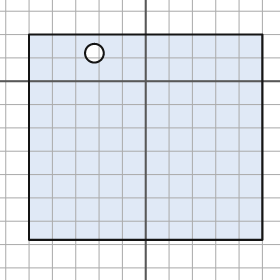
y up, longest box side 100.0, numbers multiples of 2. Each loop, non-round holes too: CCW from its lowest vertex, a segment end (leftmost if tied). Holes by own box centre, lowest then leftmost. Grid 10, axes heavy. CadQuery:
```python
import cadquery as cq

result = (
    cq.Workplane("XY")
    .moveTo(-50.0, -68.0)
    .lineTo(50.0, -68.0)
    .lineTo(50.0, 20.0)
    .lineTo(-50.0, 20.0)
    .close()
    .moveTo(-22.0, 12.0)
    .circle(4.0)
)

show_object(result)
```